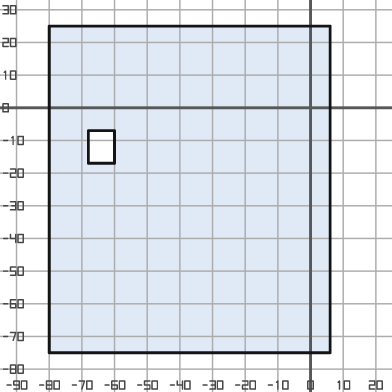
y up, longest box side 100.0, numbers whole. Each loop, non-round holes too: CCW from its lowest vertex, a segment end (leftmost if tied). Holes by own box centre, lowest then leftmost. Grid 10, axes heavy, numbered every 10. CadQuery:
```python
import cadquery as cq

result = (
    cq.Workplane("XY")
    .moveTo(-80.0, -75.0)
    .lineTo(6.0, -75.0)
    .lineTo(6.0, 25.0)
    .lineTo(-80.0, 25.0)
    .close()
    .moveTo(-68.0, -17.0)
    .lineTo(-60.0, -17.0)
    .lineTo(-60.0, -7.0)
    .lineTo(-68.0, -7.0)
    .close()
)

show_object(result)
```